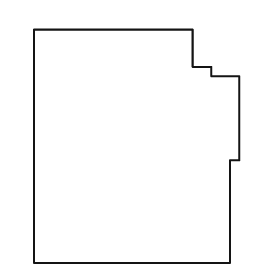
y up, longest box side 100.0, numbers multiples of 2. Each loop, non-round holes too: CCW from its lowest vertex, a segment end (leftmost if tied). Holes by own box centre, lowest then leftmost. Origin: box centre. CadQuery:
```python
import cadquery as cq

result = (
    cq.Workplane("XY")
    .moveTo(-44.0, -50.0)
    .lineTo(40.0, -50.0)
    .lineTo(40.0, -6.0)
    .lineTo(44.0, -6.0)
    .lineTo(44.0, 30.0)
    .lineTo(32.0, 30.0)
    .lineTo(32.0, 34.0)
    .lineTo(24.0, 34.0)
    .lineTo(24.0, 50.0)
    .lineTo(-44.0, 50.0)
    .close()
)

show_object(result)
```